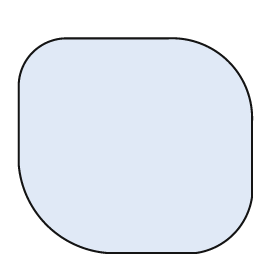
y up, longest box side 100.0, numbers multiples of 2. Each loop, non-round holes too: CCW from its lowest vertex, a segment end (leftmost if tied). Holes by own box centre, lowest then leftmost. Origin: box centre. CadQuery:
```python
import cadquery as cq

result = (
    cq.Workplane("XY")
    .moveTo(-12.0, -46.0)
    .lineTo(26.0, -46.0)
    .threePointArc((42.0, -38.0), (50.0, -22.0))
    .lineTo(50.0, 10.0)
    .threePointArc((40.0, 36.0), (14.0, 46.0))
    .lineTo(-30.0, 46.0)
    .threePointArc((-44.0, 40.0), (-50.0, 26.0))
    .lineTo(-50.0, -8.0)
    .threePointArc((-38.0, -34.0), (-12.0, -46.0))
    .close()
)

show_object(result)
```